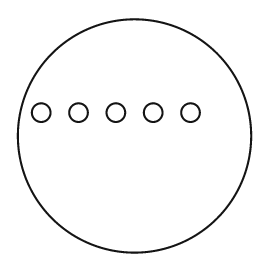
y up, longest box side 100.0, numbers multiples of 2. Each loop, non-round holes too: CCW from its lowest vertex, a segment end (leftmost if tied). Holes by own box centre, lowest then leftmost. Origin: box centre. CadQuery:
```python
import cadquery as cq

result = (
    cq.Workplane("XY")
    .moveTo(0.0, 0.0)
    .circle(50.0)
    .moveTo(-40.0, 10.0)
    .circle(4.0)
    .moveTo(-24.0, 10.0)
    .circle(4.0)
    .moveTo(-8.0, 10.0)
    .circle(4.0)
    .moveTo(8.0, 10.0)
    .circle(4.0)
    .moveTo(24.0, 10.0)
    .circle(4.0)
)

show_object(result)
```